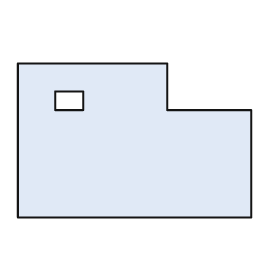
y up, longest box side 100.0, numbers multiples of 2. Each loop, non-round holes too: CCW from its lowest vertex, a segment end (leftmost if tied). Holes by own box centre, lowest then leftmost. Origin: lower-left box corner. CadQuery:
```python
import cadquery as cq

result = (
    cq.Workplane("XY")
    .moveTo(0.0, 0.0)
    .lineTo(100.0, 0.0)
    .lineTo(100.0, 46.0)
    .lineTo(64.0, 46.0)
    .lineTo(64.0, 66.0)
    .lineTo(0.0, 66.0)
    .close()
    .moveTo(16.0, 46.0)
    .lineTo(28.0, 46.0)
    .lineTo(28.0, 54.0)
    .lineTo(16.0, 54.0)
    .close()
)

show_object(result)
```